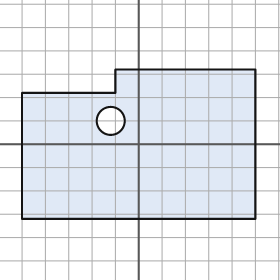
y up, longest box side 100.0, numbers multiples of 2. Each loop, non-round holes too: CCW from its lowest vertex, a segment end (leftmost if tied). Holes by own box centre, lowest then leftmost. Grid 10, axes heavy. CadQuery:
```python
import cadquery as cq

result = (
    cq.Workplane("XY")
    .moveTo(-50.0, -32.0)
    .lineTo(50.0, -32.0)
    .lineTo(50.0, 32.0)
    .lineTo(-10.0, 32.0)
    .lineTo(-10.0, 22.0)
    .lineTo(-50.0, 22.0)
    .close()
    .moveTo(-12.0, 10.0)
    .circle(6.0)
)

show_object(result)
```